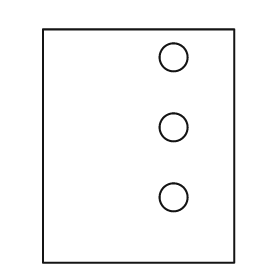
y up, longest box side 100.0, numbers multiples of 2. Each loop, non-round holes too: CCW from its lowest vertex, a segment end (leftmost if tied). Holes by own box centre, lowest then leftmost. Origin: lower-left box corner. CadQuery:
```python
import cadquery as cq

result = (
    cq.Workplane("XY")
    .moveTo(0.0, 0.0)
    .lineTo(82.0, 0.0)
    .lineTo(82.0, 100.0)
    .lineTo(0.0, 100.0)
    .close()
    .moveTo(56.0, 28.0)
    .circle(6.0)
    .moveTo(56.0, 58.0)
    .circle(6.0)
    .moveTo(56.0, 88.0)
    .circle(6.0)
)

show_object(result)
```